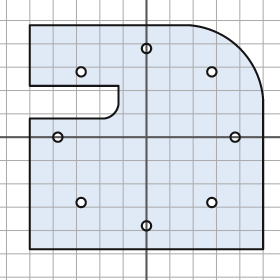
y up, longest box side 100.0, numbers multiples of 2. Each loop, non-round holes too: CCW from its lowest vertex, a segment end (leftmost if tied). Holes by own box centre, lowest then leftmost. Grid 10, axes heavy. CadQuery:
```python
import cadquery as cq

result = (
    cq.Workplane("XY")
    .moveTo(-50.0, -48.0)
    .lineTo(50.0, -48.0)
    .lineTo(50.0, 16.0)
    .threePointArc((40.0, 38.0), (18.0, 48.0))
    .lineTo(-50.0, 48.0)
    .lineTo(-50.0, 22.0)
    .lineTo(-12.0, 22.0)
    .lineTo(-12.0, 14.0)
    .threePointArc((-14.0, 10.0), (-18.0, 8.0))
    .lineTo(-50.0, 8.0)
    .close()
    .moveTo(0.0, -38.0)
    .circle(2.0)
    .moveTo(-28.0, -28.0)
    .circle(2.0)
    .moveTo(28.0, -28.0)
    .circle(2.0)
    .moveTo(-38.0, 0.0)
    .circle(2.0)
    .moveTo(38.0, 0.0)
    .circle(2.0)
    .moveTo(-28.0, 28.0)
    .circle(2.0)
    .moveTo(28.0, 28.0)
    .circle(2.0)
    .moveTo(0.0, 38.0)
    .circle(2.0)
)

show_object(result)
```